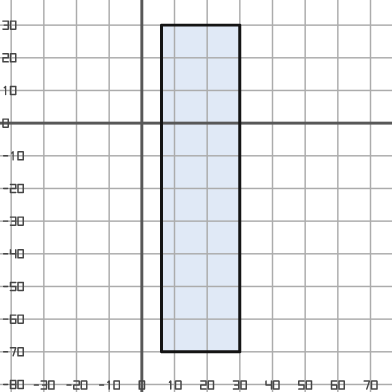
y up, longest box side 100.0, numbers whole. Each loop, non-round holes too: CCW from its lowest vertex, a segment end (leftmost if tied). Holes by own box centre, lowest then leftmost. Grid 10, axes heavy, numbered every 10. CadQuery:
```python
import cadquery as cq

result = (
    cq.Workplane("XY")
    .moveTo(6.0, -70.0)
    .lineTo(30.0, -70.0)
    .lineTo(30.0, 30.0)
    .lineTo(6.0, 30.0)
    .close()
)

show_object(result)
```